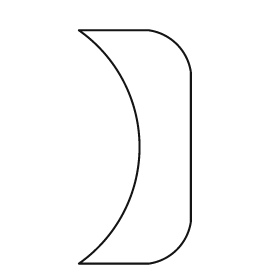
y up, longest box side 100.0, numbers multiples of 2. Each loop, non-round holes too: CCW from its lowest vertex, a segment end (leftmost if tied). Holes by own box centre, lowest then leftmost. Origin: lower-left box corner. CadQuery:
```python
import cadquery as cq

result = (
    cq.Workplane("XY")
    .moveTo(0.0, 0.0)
    .lineTo(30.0, 0.0)
    .threePointArc((42.0, 6.0), (48.0, 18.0))
    .lineTo(48.0, 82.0)
    .threePointArc((42.0, 94.0), (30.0, 100.0))
    .lineTo(0.0, 100.0)
    .threePointArc((26.0, 50.0), (0.0, 0.0))
    .close()
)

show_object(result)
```